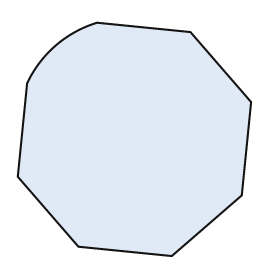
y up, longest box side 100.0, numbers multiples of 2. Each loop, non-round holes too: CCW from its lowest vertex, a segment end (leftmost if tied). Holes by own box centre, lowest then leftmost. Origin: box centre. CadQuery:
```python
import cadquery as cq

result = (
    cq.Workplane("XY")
    .moveTo(16.0, -50.0)
    .lineTo(46.0, -24.0)
    .lineTo(50.0, 16.0)
    .lineTo(24.0, 46.0)
    .lineTo(-16.0, 50.0)
    .threePointArc((-34.0, 40.0), (-46.0, 24.0))
    .lineTo(-50.0, -16.0)
    .lineTo(-24.0, -46.0)
    .close()
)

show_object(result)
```